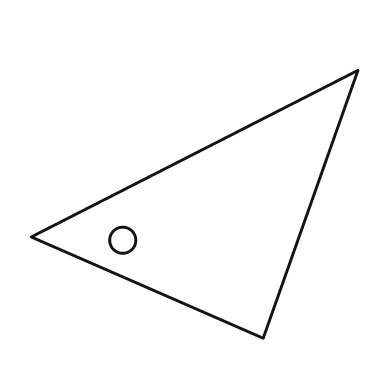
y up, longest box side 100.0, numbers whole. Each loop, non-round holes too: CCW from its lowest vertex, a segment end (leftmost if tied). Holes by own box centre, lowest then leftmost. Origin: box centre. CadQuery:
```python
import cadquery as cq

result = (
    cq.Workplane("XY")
    .moveTo(21.0, -41.0)
    .lineTo(50.0, 41.0)
    .lineTo(-50.0, -10.0)
    .close()
    .moveTo(-22.0, -11.0)
    .circle(4.0)
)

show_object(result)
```